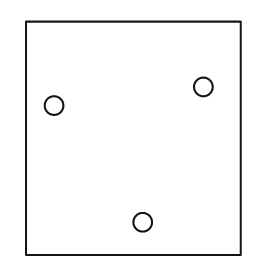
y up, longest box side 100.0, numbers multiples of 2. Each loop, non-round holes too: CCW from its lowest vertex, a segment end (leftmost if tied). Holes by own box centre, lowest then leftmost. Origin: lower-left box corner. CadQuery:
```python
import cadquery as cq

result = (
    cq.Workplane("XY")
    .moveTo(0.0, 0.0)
    .lineTo(92.0, 0.0)
    .lineTo(92.0, 100.0)
    .lineTo(0.0, 100.0)
    .close()
    .moveTo(50.0, 14.0)
    .circle(4.0)
    .moveTo(12.0, 64.0)
    .circle(4.0)
    .moveTo(76.0, 72.0)
    .circle(4.0)
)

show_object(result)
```